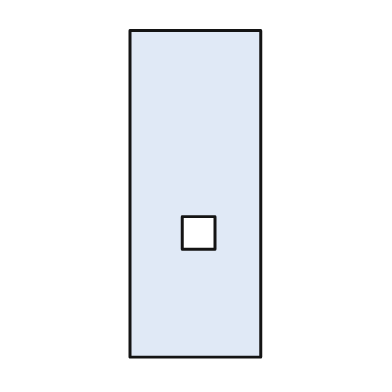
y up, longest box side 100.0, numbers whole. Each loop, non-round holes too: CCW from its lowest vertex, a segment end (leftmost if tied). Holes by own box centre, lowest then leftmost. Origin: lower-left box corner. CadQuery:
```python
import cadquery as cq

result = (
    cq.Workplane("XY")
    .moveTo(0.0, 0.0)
    .lineTo(40.0, 0.0)
    .lineTo(40.0, 100.0)
    .lineTo(0.0, 100.0)
    .close()
    .moveTo(16.0, 33.0)
    .lineTo(26.0, 33.0)
    .lineTo(26.0, 43.0)
    .lineTo(16.0, 43.0)
    .close()
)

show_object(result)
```